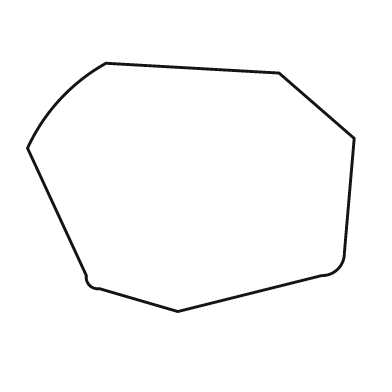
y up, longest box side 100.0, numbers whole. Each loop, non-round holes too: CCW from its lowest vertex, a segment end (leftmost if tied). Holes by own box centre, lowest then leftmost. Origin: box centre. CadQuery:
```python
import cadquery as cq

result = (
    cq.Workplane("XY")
    .moveTo(-4.0, -38.0)
    .lineTo(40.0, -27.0)
    .threePointArc((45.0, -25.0), (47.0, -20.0))
    .lineTo(50.0, 15.0)
    .lineTo(27.0, 35.0)
    .lineTo(-26.0, 38.0)
    .threePointArc((-40.0, 27.0), (-50.0, 12.0))
    .lineTo(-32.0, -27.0)
    .threePointArc((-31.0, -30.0), (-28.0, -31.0))
    .close()
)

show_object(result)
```